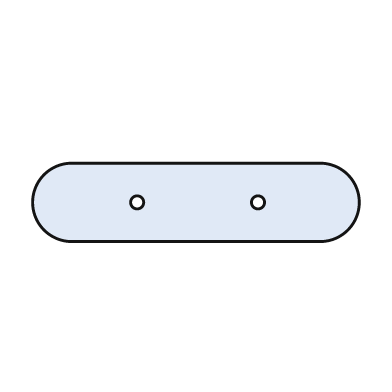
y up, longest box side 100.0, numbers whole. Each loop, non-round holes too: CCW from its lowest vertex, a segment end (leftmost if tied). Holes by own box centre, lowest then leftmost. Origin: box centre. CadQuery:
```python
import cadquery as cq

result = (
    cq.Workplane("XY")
    .moveTo(-38.0, -12.0)
    .lineTo(38.0, -12.0)
    .threePointArc((50.0, 0.0), (38.0, 12.0))
    .lineTo(-38.0, 12.0)
    .threePointArc((-50.0, 0.0), (-38.0, -12.0))
    .close()
    .moveTo(-18.0, 0.0)
    .circle(2.0)
    .moveTo(19.0, 0.0)
    .circle(2.0)
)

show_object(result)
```